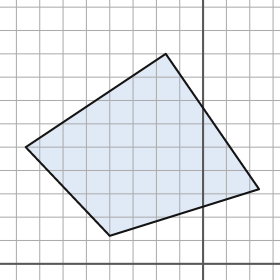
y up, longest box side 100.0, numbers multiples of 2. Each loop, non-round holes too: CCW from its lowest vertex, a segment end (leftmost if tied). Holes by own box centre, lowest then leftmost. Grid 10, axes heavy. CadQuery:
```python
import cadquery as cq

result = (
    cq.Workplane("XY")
    .moveTo(-40.0, 12.0)
    .lineTo(24.0, 32.0)
    .lineTo(-16.0, 90.0)
    .lineTo(-76.0, 50.0)
    .close()
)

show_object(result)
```